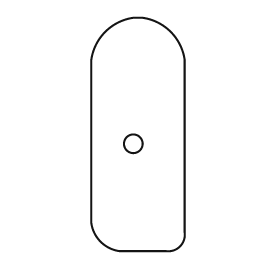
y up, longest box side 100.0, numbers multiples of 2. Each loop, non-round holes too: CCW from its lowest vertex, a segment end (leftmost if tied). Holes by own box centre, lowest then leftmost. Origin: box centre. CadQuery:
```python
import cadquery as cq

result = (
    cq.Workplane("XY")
    .moveTo(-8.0, -50.0)
    .lineTo(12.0, -50.0)
    .threePointArc((18.0, -48.0), (20.0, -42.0))
    .lineTo(20.0, 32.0)
    .threePointArc((14.0, 44.0), (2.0, 50.0))
    .lineTo(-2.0, 50.0)
    .threePointArc((-14.0, 44.0), (-20.0, 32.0))
    .lineTo(-20.0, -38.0)
    .threePointArc((-16.0, -46.0), (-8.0, -50.0))
    .close()
    .moveTo(-2.0, -4.0)
    .circle(4.0)
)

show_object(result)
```